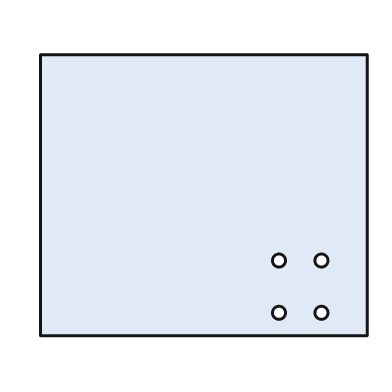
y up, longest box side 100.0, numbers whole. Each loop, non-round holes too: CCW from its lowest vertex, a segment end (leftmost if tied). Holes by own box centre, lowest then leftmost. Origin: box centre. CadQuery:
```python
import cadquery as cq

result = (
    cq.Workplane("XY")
    .moveTo(-50.0, -43.0)
    .lineTo(50.0, -43.0)
    .lineTo(50.0, 43.0)
    .lineTo(-50.0, 43.0)
    .close()
    .moveTo(23.0, -36.0)
    .circle(2.0)
    .moveTo(36.0, -36.0)
    .circle(2.0)
    .moveTo(23.0, -20.0)
    .circle(2.0)
    .moveTo(36.0, -20.0)
    .circle(2.0)
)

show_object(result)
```